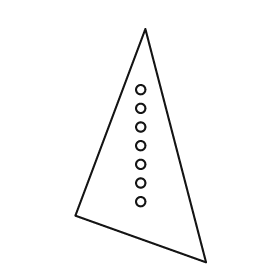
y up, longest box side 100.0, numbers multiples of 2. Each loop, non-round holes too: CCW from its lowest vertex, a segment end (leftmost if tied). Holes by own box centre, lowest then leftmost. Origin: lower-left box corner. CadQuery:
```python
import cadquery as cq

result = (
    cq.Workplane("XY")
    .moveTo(56.0, 0.0)
    .lineTo(30.0, 100.0)
    .lineTo(0.0, 20.0)
    .close()
    .moveTo(28.0, 26.0)
    .circle(2.0)
    .moveTo(28.0, 34.0)
    .circle(2.0)
    .moveTo(28.0, 42.0)
    .circle(2.0)
    .moveTo(28.0, 50.0)
    .circle(2.0)
    .moveTo(28.0, 58.0)
    .circle(2.0)
    .moveTo(28.0, 66.0)
    .circle(2.0)
    .moveTo(28.0, 74.0)
    .circle(2.0)
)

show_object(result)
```